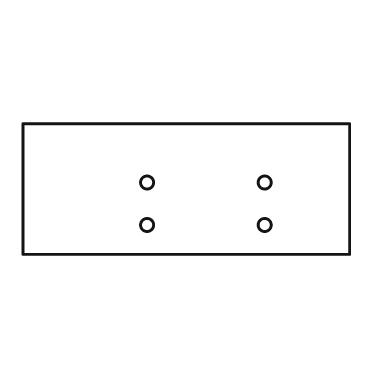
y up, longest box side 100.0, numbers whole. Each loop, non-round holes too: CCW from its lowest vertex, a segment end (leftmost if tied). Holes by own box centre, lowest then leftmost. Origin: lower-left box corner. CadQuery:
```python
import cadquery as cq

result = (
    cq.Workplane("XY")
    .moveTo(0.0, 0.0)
    .lineTo(100.0, 0.0)
    .lineTo(100.0, 40.0)
    .lineTo(0.0, 40.0)
    .close()
    .moveTo(38.0, 9.0)
    .circle(2.0)
    .moveTo(74.0, 9.0)
    .circle(2.0)
    .moveTo(38.0, 22.0)
    .circle(2.0)
    .moveTo(74.0, 22.0)
    .circle(2.0)
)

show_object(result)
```